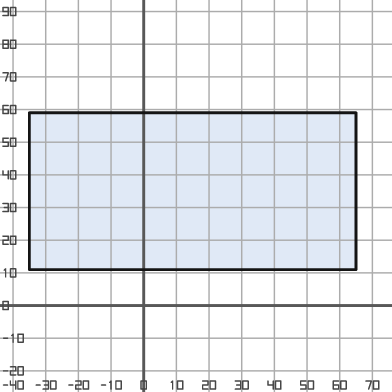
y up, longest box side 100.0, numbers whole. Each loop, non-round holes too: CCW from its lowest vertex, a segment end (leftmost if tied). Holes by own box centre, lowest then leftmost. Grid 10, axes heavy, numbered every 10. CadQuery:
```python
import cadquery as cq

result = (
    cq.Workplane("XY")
    .moveTo(-35.0, 11.0)
    .lineTo(65.0, 11.0)
    .lineTo(65.0, 59.0)
    .lineTo(-35.0, 59.0)
    .close()
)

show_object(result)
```